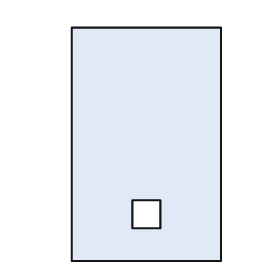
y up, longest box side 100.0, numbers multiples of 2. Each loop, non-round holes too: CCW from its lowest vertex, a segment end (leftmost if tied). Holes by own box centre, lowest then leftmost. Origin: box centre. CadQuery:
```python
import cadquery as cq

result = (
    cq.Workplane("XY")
    .moveTo(-32.0, -50.0)
    .lineTo(32.0, -50.0)
    .lineTo(32.0, 50.0)
    .lineTo(-32.0, 50.0)
    .close()
    .moveTo(-6.0, -36.0)
    .lineTo(6.0, -36.0)
    .lineTo(6.0, -24.0)
    .lineTo(-6.0, -24.0)
    .close()
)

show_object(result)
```